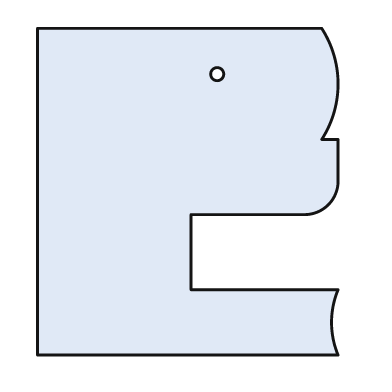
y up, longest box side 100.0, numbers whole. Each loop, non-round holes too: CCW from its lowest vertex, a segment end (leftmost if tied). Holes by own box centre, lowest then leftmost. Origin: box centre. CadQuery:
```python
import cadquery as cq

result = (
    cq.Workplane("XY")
    .moveTo(-46.0, -50.0)
    .lineTo(46.0, -50.0)
    .threePointArc((44.0, -40.0), (46.0, -30.0))
    .lineTo(1.0, -30.0)
    .lineTo(1.0, -7.0)
    .lineTo(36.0, -7.0)
    .threePointArc((43.0, -4.0), (46.0, 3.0))
    .lineTo(46.0, 16.0)
    .lineTo(41.0, 16.0)
    .threePointArc((46.0, 33.0), (41.0, 50.0))
    .lineTo(-46.0, 50.0)
    .close()
    .moveTo(9.0, 36.0)
    .circle(2.0)
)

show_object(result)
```